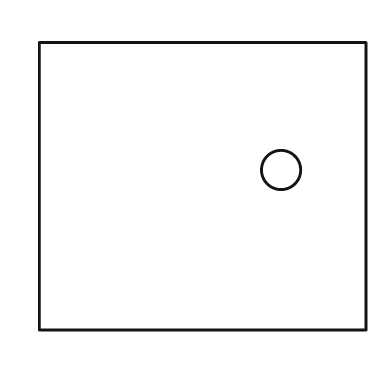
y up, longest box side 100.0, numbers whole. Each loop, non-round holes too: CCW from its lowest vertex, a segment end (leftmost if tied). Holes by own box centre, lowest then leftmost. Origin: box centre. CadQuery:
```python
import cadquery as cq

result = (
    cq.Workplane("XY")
    .moveTo(-50.0, -44.0)
    .lineTo(50.0, -44.0)
    .lineTo(50.0, 44.0)
    .lineTo(-50.0, 44.0)
    .close()
    .moveTo(24.0, 5.0)
    .circle(6.0)
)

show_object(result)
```